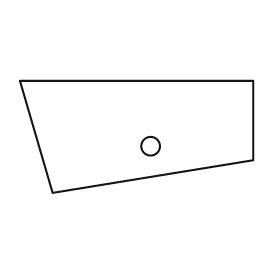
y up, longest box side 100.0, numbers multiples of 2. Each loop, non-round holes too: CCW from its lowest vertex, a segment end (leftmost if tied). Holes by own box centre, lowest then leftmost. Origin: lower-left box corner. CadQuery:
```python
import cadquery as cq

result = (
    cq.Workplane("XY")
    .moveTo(14.0, 0.0)
    .lineTo(100.0, 14.0)
    .lineTo(100.0, 48.0)
    .lineTo(0.0, 48.0)
    .close()
    .moveTo(56.0, 20.0)
    .circle(4.0)
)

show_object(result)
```